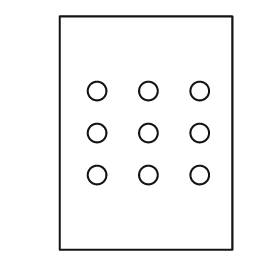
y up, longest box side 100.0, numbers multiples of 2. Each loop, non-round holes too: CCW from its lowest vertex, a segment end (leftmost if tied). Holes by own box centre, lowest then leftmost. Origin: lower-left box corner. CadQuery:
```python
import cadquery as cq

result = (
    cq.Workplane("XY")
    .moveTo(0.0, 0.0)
    .lineTo(74.0, 0.0)
    .lineTo(74.0, 100.0)
    .lineTo(0.0, 100.0)
    .close()
    .moveTo(16.0, 32.0)
    .circle(4.0)
    .moveTo(38.0, 32.0)
    .circle(4.0)
    .moveTo(60.0, 32.0)
    .circle(4.0)
    .moveTo(16.0, 50.0)
    .circle(4.0)
    .moveTo(38.0, 50.0)
    .circle(4.0)
    .moveTo(60.0, 50.0)
    .circle(4.0)
    .moveTo(16.0, 68.0)
    .circle(4.0)
    .moveTo(38.0, 68.0)
    .circle(4.0)
    .moveTo(60.0, 68.0)
    .circle(4.0)
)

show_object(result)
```